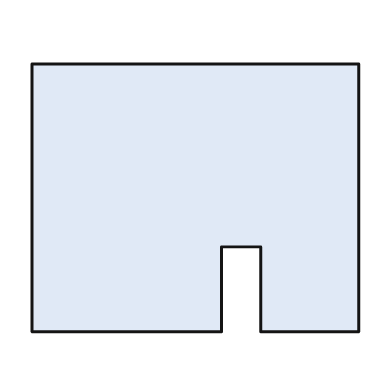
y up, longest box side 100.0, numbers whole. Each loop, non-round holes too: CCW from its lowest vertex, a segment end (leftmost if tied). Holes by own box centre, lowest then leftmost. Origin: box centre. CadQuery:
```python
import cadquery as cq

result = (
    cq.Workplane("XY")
    .moveTo(-50.0, -41.0)
    .lineTo(8.0, -41.0)
    .lineTo(8.0, -15.0)
    .lineTo(20.0, -15.0)
    .lineTo(20.0, -41.0)
    .lineTo(50.0, -41.0)
    .lineTo(50.0, 41.0)
    .lineTo(-50.0, 41.0)
    .close()
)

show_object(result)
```